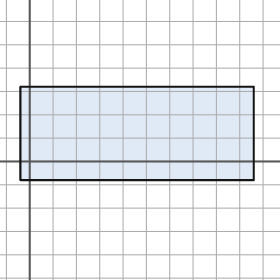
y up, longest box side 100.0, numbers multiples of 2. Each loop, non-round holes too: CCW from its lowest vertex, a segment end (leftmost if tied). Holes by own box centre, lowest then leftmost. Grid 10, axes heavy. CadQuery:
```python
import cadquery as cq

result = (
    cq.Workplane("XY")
    .moveTo(-4.0, -8.0)
    .lineTo(96.0, -8.0)
    .lineTo(96.0, 32.0)
    .lineTo(-4.0, 32.0)
    .close()
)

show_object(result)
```